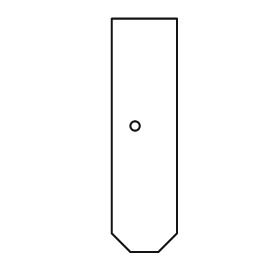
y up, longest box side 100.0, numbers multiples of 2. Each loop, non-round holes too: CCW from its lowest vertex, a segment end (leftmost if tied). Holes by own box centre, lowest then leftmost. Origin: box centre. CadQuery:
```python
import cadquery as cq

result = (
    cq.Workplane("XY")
    .moveTo(-6.0, -50.0)
    .lineTo(6.0, -50.0)
    .lineTo(14.0, -42.0)
    .lineTo(14.0, 50.0)
    .lineTo(-14.0, 50.0)
    .lineTo(-14.0, -42.0)
    .close()
    .moveTo(-4.0, 4.0)
    .circle(2.0)
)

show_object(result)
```